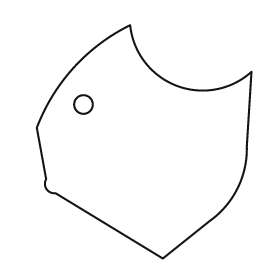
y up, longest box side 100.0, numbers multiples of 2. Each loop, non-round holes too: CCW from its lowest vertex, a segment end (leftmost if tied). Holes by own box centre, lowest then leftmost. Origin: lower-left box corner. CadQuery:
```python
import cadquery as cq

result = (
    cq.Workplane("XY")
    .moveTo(54.0, 0.0)
    .lineTo(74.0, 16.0)
    .threePointArc((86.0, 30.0), (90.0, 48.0))
    .lineTo(92.0, 80.0)
    .threePointArc((60.0, 74.0), (40.0, 100.0))
    .threePointArc((16.0, 82.0), (0.0, 56.0))
    .lineTo(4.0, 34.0)
    .threePointArc((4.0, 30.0), (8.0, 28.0))
    .close()
    .moveTo(20.0, 66.0)
    .circle(4.0)
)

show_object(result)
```